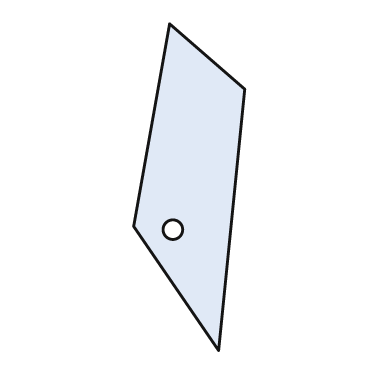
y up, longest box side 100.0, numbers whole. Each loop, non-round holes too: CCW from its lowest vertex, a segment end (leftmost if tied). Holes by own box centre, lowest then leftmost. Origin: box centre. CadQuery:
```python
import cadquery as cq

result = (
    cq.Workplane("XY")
    .moveTo(9.0, -50.0)
    .lineTo(17.0, 30.0)
    .lineTo(-6.0, 50.0)
    .lineTo(-17.0, -12.0)
    .close()
    .moveTo(-5.0, -13.0)
    .circle(3.0)
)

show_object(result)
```